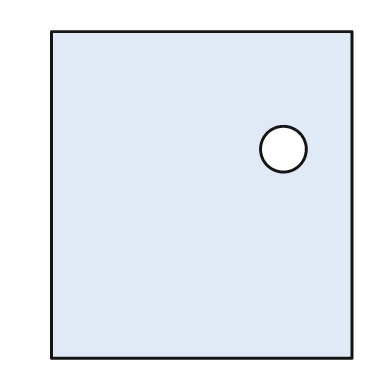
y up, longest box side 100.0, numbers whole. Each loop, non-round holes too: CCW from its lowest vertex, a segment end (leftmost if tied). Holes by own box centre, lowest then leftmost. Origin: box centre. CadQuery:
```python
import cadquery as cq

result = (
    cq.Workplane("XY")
    .moveTo(-46.0, -50.0)
    .lineTo(46.0, -50.0)
    .lineTo(46.0, 50.0)
    .lineTo(-46.0, 50.0)
    .close()
    .moveTo(25.0, 14.0)
    .circle(7.0)
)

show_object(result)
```